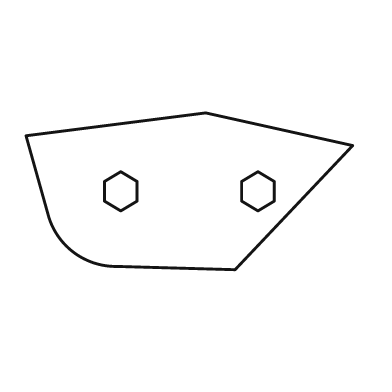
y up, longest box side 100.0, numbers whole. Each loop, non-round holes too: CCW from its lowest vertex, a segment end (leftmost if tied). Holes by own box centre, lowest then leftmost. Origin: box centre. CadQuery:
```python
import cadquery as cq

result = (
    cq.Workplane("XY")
    .moveTo(14.0, -24.0)
    .lineTo(50.0, 14.0)
    .lineTo(5.0, 24.0)
    .lineTo(-50.0, 17.0)
    .lineTo(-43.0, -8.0)
    .threePointArc((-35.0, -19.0), (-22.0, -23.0))
    .close()
    .moveTo(-21.0, -6.0)
    .lineTo(-16.0, -3.0)
    .lineTo(-16.0, 3.0)
    .lineTo(-21.0, 6.0)
    .lineTo(-26.0, 3.0)
    .lineTo(-26.0, -3.0)
    .close()
    .moveTo(21.0, -6.0)
    .lineTo(26.0, -3.0)
    .lineTo(26.0, 3.0)
    .lineTo(21.0, 6.0)
    .lineTo(16.0, 3.0)
    .lineTo(16.0, -3.0)
    .close()
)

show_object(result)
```